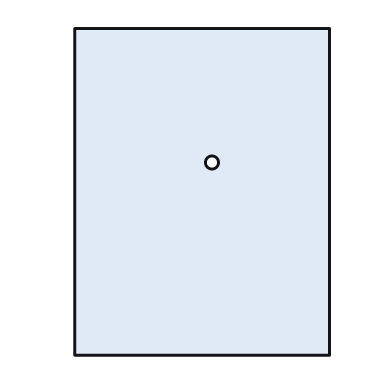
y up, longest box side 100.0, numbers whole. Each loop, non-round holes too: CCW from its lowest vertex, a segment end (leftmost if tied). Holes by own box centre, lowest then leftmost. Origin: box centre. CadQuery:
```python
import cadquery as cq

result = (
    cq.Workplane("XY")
    .moveTo(-39.0, -50.0)
    .lineTo(39.0, -50.0)
    .lineTo(39.0, 50.0)
    .lineTo(-39.0, 50.0)
    .close()
    .moveTo(3.0, 9.0)
    .circle(2.0)
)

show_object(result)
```